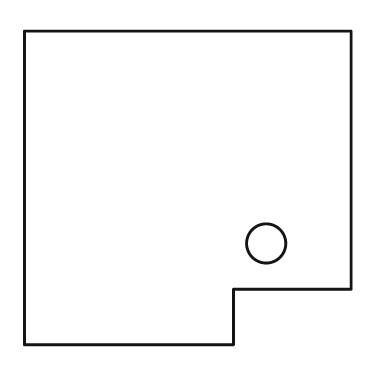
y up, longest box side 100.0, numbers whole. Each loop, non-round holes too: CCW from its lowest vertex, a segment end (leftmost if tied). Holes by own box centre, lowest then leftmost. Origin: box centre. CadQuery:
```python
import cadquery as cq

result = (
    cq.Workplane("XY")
    .moveTo(-50.0, -48.0)
    .lineTo(14.0, -48.0)
    .lineTo(14.0, -31.0)
    .lineTo(50.0, -31.0)
    .lineTo(50.0, 48.0)
    .lineTo(-50.0, 48.0)
    .close()
    .moveTo(24.0, -17.0)
    .circle(6.0)
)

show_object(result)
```